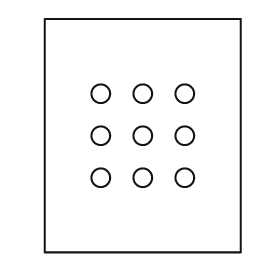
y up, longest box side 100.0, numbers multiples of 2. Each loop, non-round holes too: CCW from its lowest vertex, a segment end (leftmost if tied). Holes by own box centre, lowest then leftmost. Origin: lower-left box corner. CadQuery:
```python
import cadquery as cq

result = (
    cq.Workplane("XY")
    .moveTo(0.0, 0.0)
    .lineTo(84.0, 0.0)
    .lineTo(84.0, 100.0)
    .lineTo(0.0, 100.0)
    .close()
    .moveTo(24.0, 32.0)
    .circle(4.0)
    .moveTo(42.0, 32.0)
    .circle(4.0)
    .moveTo(60.0, 32.0)
    .circle(4.0)
    .moveTo(24.0, 50.0)
    .circle(4.0)
    .moveTo(42.0, 50.0)
    .circle(4.0)
    .moveTo(60.0, 50.0)
    .circle(4.0)
    .moveTo(24.0, 68.0)
    .circle(4.0)
    .moveTo(42.0, 68.0)
    .circle(4.0)
    .moveTo(60.0, 68.0)
    .circle(4.0)
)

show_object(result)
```